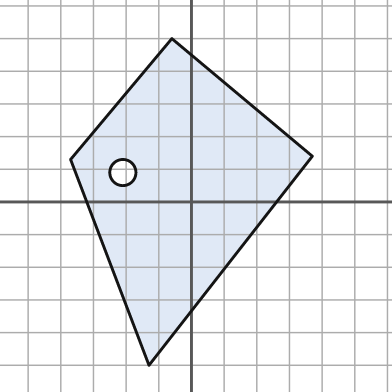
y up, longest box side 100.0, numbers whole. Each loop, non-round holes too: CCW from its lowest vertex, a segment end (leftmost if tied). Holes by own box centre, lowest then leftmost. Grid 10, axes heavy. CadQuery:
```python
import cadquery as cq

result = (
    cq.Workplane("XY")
    .moveTo(-13.0, -50.0)
    .lineTo(37.0, 14.0)
    .lineTo(-6.0, 50.0)
    .lineTo(-37.0, 13.0)
    .close()
    .moveTo(-21.0, 9.0)
    .circle(4.0)
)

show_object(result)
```